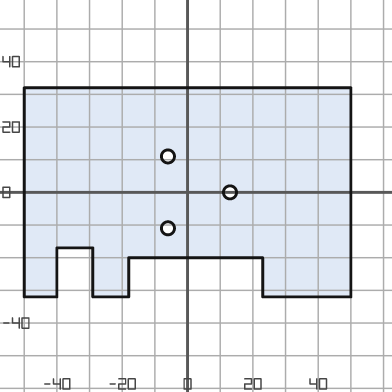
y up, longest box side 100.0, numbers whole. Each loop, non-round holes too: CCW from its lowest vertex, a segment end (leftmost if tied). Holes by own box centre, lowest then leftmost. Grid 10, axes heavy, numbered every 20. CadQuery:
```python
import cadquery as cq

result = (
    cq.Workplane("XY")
    .moveTo(-50.0, -32.0)
    .lineTo(-40.0, -32.0)
    .lineTo(-40.0, -17.0)
    .lineTo(-29.0, -17.0)
    .lineTo(-29.0, -32.0)
    .lineTo(-18.0, -32.0)
    .lineTo(-18.0, -20.0)
    .lineTo(23.0, -20.0)
    .lineTo(23.0, -32.0)
    .lineTo(50.0, -32.0)
    .lineTo(50.0, 32.0)
    .lineTo(-50.0, 32.0)
    .close()
    .moveTo(-6.0, -11.0)
    .circle(2.0)
    .moveTo(13.0, 0.0)
    .circle(2.0)
    .moveTo(-6.0, 11.0)
    .circle(2.0)
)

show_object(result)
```